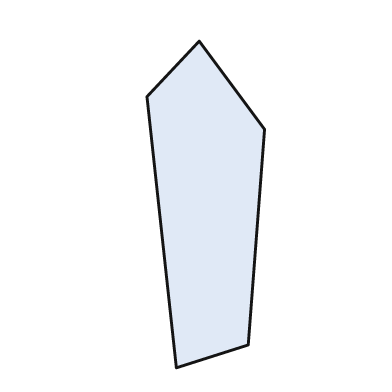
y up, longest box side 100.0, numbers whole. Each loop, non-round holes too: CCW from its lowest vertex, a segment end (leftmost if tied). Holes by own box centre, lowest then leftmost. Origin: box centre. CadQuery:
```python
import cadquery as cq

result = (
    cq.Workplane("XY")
    .moveTo(-9.0, -50.0)
    .lineTo(13.0, -43.0)
    .lineTo(18.0, 23.0)
    .lineTo(-2.0, 50.0)
    .lineTo(-18.0, 33.0)
    .close()
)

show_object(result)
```